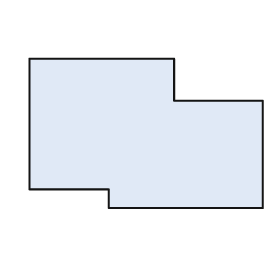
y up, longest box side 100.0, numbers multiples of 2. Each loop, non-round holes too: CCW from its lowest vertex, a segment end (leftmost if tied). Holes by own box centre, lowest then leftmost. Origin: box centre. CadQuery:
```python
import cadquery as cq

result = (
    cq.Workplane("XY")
    .moveTo(-16.0, -32.0)
    .lineTo(50.0, -32.0)
    .lineTo(50.0, 14.0)
    .lineTo(12.0, 14.0)
    .lineTo(12.0, 32.0)
    .lineTo(-50.0, 32.0)
    .lineTo(-50.0, -24.0)
    .lineTo(-16.0, -24.0)
    .close()
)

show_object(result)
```